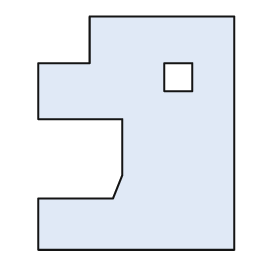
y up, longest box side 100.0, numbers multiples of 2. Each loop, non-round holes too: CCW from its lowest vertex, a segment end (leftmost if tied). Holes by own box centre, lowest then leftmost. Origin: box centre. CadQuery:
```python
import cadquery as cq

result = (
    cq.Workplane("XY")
    .moveTo(-42.0, -50.0)
    .lineTo(42.0, -50.0)
    .lineTo(42.0, 50.0)
    .lineTo(-20.0, 50.0)
    .lineTo(-20.0, 30.0)
    .lineTo(-42.0, 30.0)
    .lineTo(-42.0, 6.0)
    .lineTo(-6.0, 6.0)
    .lineTo(-6.0, -18.0)
    .lineTo(-10.0, -28.0)
    .lineTo(-42.0, -28.0)
    .close()
    .moveTo(12.0, 18.0)
    .lineTo(24.0, 18.0)
    .lineTo(24.0, 30.0)
    .lineTo(12.0, 30.0)
    .close()
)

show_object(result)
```